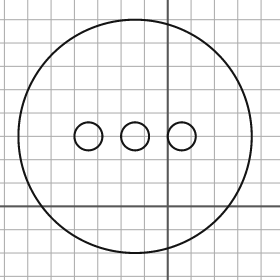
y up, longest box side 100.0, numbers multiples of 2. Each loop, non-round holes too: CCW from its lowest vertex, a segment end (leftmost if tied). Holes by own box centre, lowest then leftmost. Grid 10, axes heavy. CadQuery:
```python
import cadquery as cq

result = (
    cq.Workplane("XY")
    .moveTo(-14.0, 30.0)
    .circle(50.0)
    .moveTo(-34.0, 30.0)
    .circle(6.0)
    .moveTo(-14.0, 30.0)
    .circle(6.0)
    .moveTo(6.0, 30.0)
    .circle(6.0)
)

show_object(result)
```